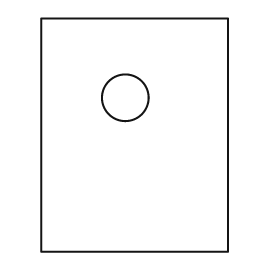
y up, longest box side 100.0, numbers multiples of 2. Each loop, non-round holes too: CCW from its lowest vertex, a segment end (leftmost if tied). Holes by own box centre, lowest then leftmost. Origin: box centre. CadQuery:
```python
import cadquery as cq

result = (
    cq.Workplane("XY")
    .moveTo(-40.0, -50.0)
    .lineTo(40.0, -50.0)
    .lineTo(40.0, 50.0)
    .lineTo(-40.0, 50.0)
    .close()
    .moveTo(-4.0, 16.0)
    .circle(10.0)
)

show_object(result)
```